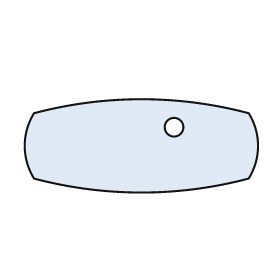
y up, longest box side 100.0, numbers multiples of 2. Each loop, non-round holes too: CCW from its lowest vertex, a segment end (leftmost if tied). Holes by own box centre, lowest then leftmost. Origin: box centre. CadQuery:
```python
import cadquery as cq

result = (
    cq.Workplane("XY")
    .moveTo(-46.0, -14.0)
    .threePointArc((0.0, -20.0), (46.0, -14.0))
    .threePointArc((50.0, 0.0), (46.0, 14.0))
    .threePointArc((0.0, 20.0), (-46.0, 14.0))
    .threePointArc((-50.0, 0.0), (-46.0, -14.0))
    .close()
    .moveTo(14.0, 8.0)
    .circle(4.0)
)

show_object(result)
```